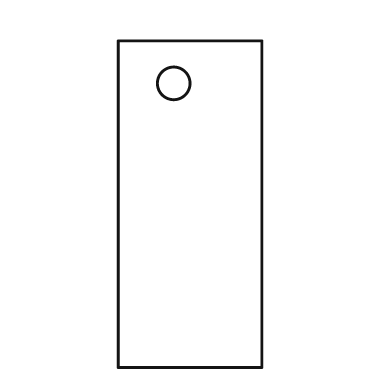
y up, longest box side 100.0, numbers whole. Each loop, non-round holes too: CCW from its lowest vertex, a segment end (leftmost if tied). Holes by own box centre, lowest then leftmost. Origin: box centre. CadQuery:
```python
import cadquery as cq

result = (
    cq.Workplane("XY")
    .moveTo(-22.0, -50.0)
    .lineTo(22.0, -50.0)
    .lineTo(22.0, 50.0)
    .lineTo(-22.0, 50.0)
    .close()
    .moveTo(-5.0, 37.0)
    .circle(5.0)
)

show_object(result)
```